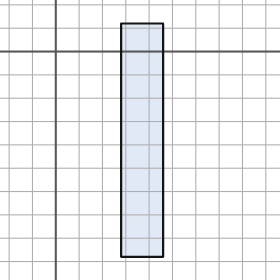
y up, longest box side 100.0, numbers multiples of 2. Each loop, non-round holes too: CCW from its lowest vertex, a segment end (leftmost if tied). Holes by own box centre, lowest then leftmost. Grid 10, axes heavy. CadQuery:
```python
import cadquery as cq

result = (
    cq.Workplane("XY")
    .moveTo(28.0, -88.0)
    .lineTo(46.0, -88.0)
    .lineTo(46.0, 12.0)
    .lineTo(28.0, 12.0)
    .close()
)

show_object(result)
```